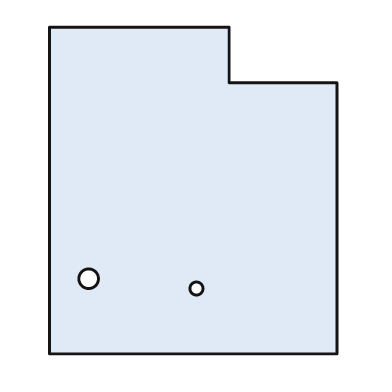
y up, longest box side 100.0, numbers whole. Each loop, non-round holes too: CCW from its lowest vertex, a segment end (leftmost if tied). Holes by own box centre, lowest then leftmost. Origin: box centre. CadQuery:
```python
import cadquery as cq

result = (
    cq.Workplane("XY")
    .moveTo(-44.0, -50.0)
    .lineTo(44.0, -50.0)
    .lineTo(44.0, 33.0)
    .lineTo(11.0, 33.0)
    .lineTo(11.0, 50.0)
    .lineTo(-44.0, 50.0)
    .close()
    .moveTo(1.0, -30.0)
    .circle(2.0)
    .moveTo(-32.0, -27.0)
    .circle(3.0)
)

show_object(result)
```